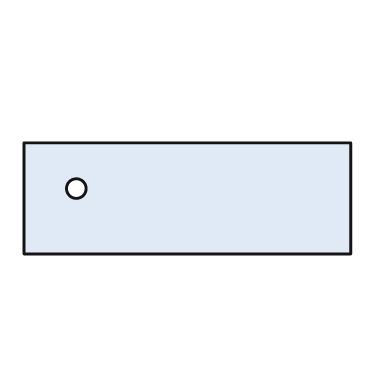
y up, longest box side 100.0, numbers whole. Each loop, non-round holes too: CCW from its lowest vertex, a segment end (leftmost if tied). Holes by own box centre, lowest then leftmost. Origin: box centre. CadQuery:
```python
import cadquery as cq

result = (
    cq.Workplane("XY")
    .moveTo(-50.0, -17.0)
    .lineTo(50.0, -17.0)
    .lineTo(50.0, 17.0)
    .lineTo(-50.0, 17.0)
    .close()
    .moveTo(-34.0, 3.0)
    .circle(3.0)
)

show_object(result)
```